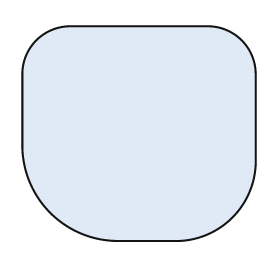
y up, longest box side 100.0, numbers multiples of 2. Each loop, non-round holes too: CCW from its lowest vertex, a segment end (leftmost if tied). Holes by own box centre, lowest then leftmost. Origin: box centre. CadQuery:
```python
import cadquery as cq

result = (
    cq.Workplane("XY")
    .moveTo(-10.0, -46.0)
    .lineTo(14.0, -46.0)
    .threePointArc((40.0, -36.0), (50.0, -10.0))
    .lineTo(50.0, 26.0)
    .threePointArc((44.0, 40.0), (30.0, 46.0))
    .lineTo(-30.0, 46.0)
    .threePointArc((-44.0, 40.0), (-50.0, 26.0))
    .lineTo(-50.0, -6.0)
    .threePointArc((-38.0, -34.0), (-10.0, -46.0))
    .close()
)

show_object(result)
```